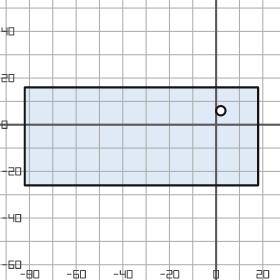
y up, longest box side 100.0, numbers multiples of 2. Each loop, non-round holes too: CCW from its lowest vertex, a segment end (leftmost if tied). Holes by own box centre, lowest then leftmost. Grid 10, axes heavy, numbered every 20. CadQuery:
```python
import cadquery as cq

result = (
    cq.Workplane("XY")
    .moveTo(-82.0, -26.0)
    .lineTo(18.0, -26.0)
    .lineTo(18.0, 16.0)
    .lineTo(-82.0, 16.0)
    .close()
    .moveTo(2.0, 6.0)
    .circle(2.0)
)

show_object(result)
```